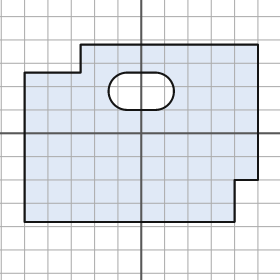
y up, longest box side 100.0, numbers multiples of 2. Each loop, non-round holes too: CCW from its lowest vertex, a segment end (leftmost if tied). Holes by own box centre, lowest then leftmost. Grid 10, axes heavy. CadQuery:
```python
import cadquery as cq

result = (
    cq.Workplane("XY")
    .moveTo(-50.0, -38.0)
    .lineTo(40.0, -38.0)
    .lineTo(40.0, -20.0)
    .lineTo(50.0, -20.0)
    .lineTo(50.0, 38.0)
    .lineTo(-26.0, 38.0)
    .lineTo(-26.0, 26.0)
    .lineTo(-50.0, 26.0)
    .close()
    .moveTo(-6.0, 10.0)
    .lineTo(6.0, 10.0)
    .threePointArc((14.0, 18.0), (6.0, 26.0))
    .lineTo(-6.0, 26.0)
    .threePointArc((-14.0, 18.0), (-6.0, 10.0))
    .close()
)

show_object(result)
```